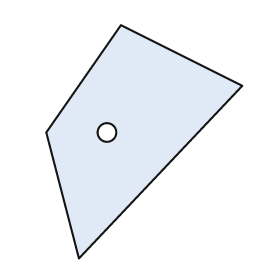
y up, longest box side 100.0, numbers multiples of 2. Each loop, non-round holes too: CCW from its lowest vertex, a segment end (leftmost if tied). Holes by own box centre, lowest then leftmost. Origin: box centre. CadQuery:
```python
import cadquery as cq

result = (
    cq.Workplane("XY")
    .moveTo(-28.0, -50.0)
    .lineTo(42.0, 24.0)
    .lineTo(-10.0, 50.0)
    .lineTo(-42.0, 4.0)
    .close()
    .moveTo(-16.0, 4.0)
    .circle(4.0)
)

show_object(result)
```